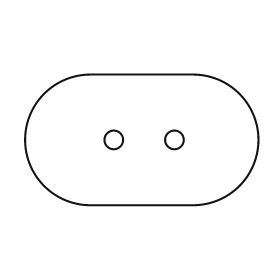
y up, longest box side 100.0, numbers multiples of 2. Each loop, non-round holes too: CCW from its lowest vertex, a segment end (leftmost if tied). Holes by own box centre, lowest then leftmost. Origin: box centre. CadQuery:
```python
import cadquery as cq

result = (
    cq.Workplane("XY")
    .moveTo(-22.0, -28.0)
    .lineTo(22.0, -28.0)
    .threePointArc((50.0, 0.0), (22.0, 28.0))
    .lineTo(-22.0, 28.0)
    .threePointArc((-50.0, 0.0), (-22.0, -28.0))
    .close()
    .moveTo(-12.0, 0.0)
    .circle(4.0)
    .moveTo(14.0, 0.0)
    .circle(4.0)
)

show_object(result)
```